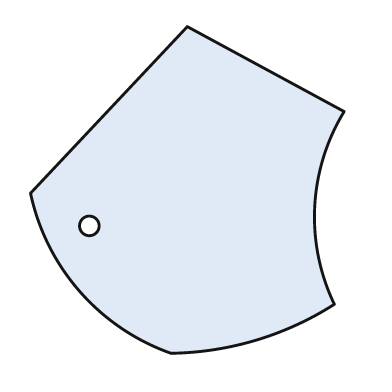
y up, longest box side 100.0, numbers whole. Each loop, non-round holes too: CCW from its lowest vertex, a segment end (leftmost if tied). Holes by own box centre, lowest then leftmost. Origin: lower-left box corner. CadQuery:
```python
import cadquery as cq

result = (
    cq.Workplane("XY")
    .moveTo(43.0, 0.0)
    .threePointArc((69.0, 4.0), (93.0, 15.0))
    .threePointArc((87.0, 45.0), (96.0, 74.0))
    .lineTo(48.0, 100.0)
    .lineTo(0.0, 49.0)
    .threePointArc((15.0, 19.0), (43.0, 0.0))
    .close()
    .moveTo(18.0, 39.0)
    .circle(3.0)
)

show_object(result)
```